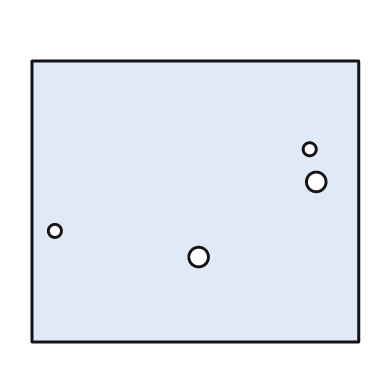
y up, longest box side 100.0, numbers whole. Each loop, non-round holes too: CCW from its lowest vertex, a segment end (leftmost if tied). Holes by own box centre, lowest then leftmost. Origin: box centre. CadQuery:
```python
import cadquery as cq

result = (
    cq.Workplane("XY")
    .moveTo(-50.0, -43.0)
    .lineTo(50.0, -43.0)
    .lineTo(50.0, 43.0)
    .lineTo(-50.0, 43.0)
    .close()
    .moveTo(1.0, -17.0)
    .circle(3.0)
    .moveTo(-43.0, -9.0)
    .circle(2.0)
    .moveTo(37.0, 6.0)
    .circle(3.0)
    .moveTo(35.0, 16.0)
    .circle(2.0)
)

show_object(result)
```